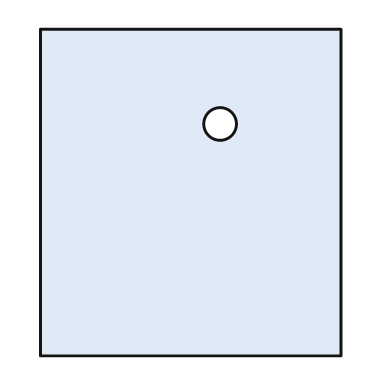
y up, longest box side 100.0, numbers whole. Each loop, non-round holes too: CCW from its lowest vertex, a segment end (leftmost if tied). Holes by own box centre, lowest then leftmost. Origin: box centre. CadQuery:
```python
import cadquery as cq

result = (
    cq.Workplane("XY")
    .moveTo(-46.0, -50.0)
    .lineTo(46.0, -50.0)
    .lineTo(46.0, 50.0)
    .lineTo(-46.0, 50.0)
    .close()
    .moveTo(9.0, 21.0)
    .circle(5.0)
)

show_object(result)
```